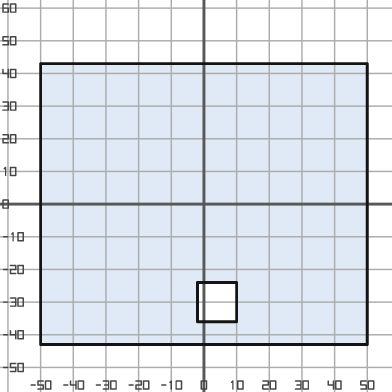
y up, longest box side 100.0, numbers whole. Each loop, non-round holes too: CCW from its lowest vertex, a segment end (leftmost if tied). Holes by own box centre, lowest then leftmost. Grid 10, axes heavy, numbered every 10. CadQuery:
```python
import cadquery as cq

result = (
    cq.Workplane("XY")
    .moveTo(-50.0, -43.0)
    .lineTo(50.0, -43.0)
    .lineTo(50.0, 43.0)
    .lineTo(-50.0, 43.0)
    .close()
    .moveTo(-2.0, -36.0)
    .lineTo(10.0, -36.0)
    .lineTo(10.0, -24.0)
    .lineTo(-2.0, -24.0)
    .close()
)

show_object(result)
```